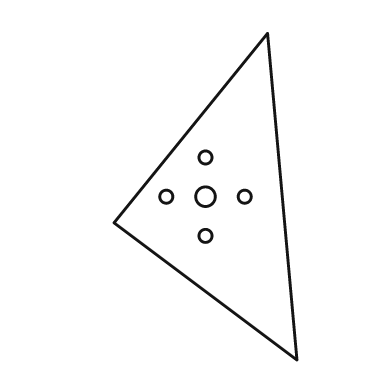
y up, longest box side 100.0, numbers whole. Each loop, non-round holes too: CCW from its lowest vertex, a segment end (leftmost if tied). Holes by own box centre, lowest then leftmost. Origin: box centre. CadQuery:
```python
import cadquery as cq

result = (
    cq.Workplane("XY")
    .moveTo(28.0, -50.0)
    .lineTo(19.0, 50.0)
    .lineTo(-28.0, -8.0)
    .close()
    .moveTo(0.0, -12.0)
    .circle(2.0)
    .moveTo(-12.0, 0.0)
    .circle(2.0)
    .moveTo(0.0, 0.0)
    .circle(3.0)
    .moveTo(12.0, 0.0)
    .circle(2.0)
    .moveTo(0.0, 12.0)
    .circle(2.0)
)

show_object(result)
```